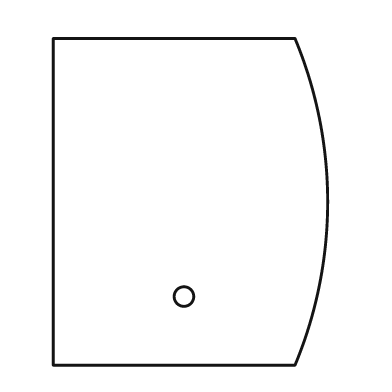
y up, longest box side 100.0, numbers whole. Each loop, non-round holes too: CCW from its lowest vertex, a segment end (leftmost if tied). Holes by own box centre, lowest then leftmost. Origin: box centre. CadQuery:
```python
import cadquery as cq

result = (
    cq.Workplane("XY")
    .moveTo(-42.0, -50.0)
    .lineTo(32.0, -50.0)
    .threePointArc((42.0, 0.0), (32.0, 50.0))
    .lineTo(-42.0, 50.0)
    .close()
    .moveTo(-2.0, -29.0)
    .circle(3.0)
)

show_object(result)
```